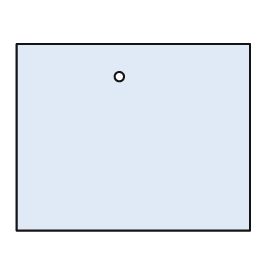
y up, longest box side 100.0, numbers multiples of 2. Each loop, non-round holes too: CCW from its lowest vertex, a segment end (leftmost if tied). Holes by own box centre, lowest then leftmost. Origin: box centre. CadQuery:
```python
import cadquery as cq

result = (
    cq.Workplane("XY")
    .moveTo(-50.0, -40.0)
    .lineTo(50.0, -40.0)
    .lineTo(50.0, 40.0)
    .lineTo(-50.0, 40.0)
    .close()
    .moveTo(-6.0, 26.0)
    .circle(2.0)
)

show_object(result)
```